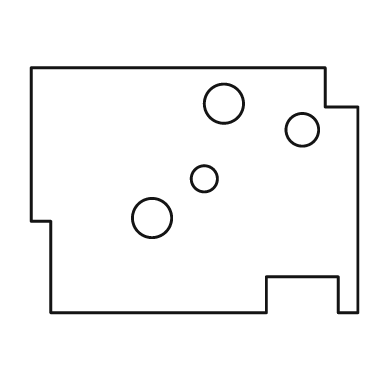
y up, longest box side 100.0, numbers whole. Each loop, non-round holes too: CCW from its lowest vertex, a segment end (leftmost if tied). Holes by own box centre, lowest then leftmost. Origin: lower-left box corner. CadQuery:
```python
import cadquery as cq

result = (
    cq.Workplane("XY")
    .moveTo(6.0, 0.0)
    .lineTo(72.0, 0.0)
    .lineTo(72.0, 11.0)
    .lineTo(94.0, 11.0)
    .lineTo(94.0, 0.0)
    .lineTo(100.0, 0.0)
    .lineTo(100.0, 63.0)
    .lineTo(90.0, 63.0)
    .lineTo(90.0, 75.0)
    .lineTo(0.0, 75.0)
    .lineTo(0.0, 28.0)
    .lineTo(6.0, 28.0)
    .close()
    .moveTo(37.0, 29.0)
    .circle(6.0)
    .moveTo(53.0, 41.0)
    .circle(4.0)
    .moveTo(83.0, 56.0)
    .circle(5.0)
    .moveTo(59.0, 64.0)
    .circle(6.0)
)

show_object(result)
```